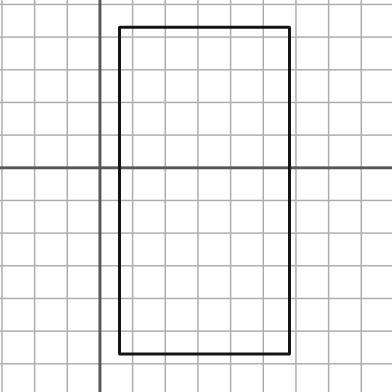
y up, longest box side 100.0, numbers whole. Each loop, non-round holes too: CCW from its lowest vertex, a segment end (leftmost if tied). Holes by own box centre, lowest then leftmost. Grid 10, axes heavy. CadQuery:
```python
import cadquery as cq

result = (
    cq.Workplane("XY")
    .moveTo(6.0, -57.0)
    .lineTo(58.0, -57.0)
    .lineTo(58.0, 43.0)
    .lineTo(6.0, 43.0)
    .close()
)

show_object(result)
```